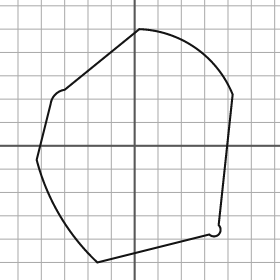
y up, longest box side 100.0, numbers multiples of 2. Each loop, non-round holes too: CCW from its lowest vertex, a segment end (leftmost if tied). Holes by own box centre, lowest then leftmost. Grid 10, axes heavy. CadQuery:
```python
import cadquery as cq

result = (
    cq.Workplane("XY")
    .moveTo(-16.0, -50.0)
    .lineTo(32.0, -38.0)
    .threePointArc((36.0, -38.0), (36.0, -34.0))
    .lineTo(42.0, 22.0)
    .threePointArc((26.0, 42.0), (2.0, 50.0))
    .lineTo(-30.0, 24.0)
    .threePointArc((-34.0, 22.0), (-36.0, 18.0))
    .lineTo(-42.0, -6.0)
    .threePointArc((-32.0, -30.0), (-16.0, -50.0))
    .close()
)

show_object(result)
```